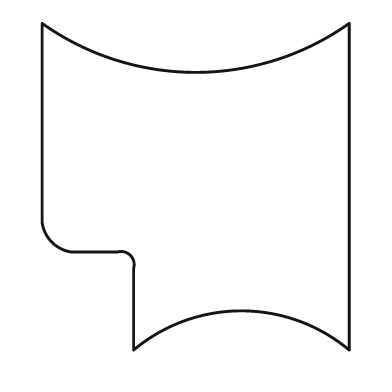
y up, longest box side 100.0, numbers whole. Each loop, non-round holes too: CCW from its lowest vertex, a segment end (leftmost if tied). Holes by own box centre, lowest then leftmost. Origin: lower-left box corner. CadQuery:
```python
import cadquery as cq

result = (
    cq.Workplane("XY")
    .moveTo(28.0, 0.0)
    .threePointArc((61.0, 12.0), (94.0, 0.0))
    .lineTo(94.0, 100.0)
    .threePointArc((47.0, 85.0), (0.0, 100.0))
    .lineTo(0.0, 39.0)
    .threePointArc((3.0, 33.0), (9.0, 30.0))
    .lineTo(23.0, 30.0)
    .threePointArc((27.0, 29.0), (28.0, 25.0))
    .close()
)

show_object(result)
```